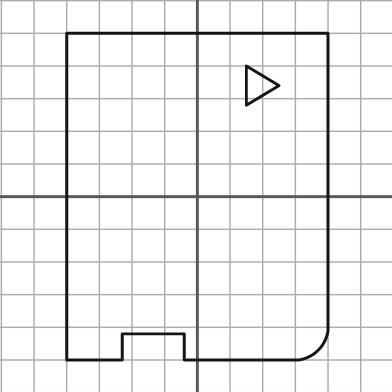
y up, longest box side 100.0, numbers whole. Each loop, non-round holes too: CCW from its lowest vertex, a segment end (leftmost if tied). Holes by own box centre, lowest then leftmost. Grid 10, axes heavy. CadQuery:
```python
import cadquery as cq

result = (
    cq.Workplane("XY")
    .moveTo(-40.0, -50.0)
    .lineTo(-23.0, -50.0)
    .lineTo(-23.0, -42.0)
    .lineTo(-4.0, -42.0)
    .lineTo(-4.0, -50.0)
    .lineTo(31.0, -50.0)
    .threePointArc((37.0, -47.0), (40.0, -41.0))
    .lineTo(40.0, 50.0)
    .lineTo(-40.0, 50.0)
    .close()
    .moveTo(15.0, 28.0)
    .lineTo(25.0, 34.0)
    .lineTo(15.0, 40.0)
    .close()
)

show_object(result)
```